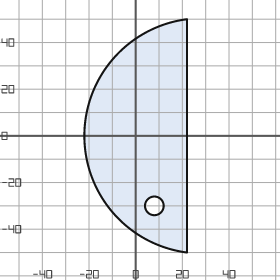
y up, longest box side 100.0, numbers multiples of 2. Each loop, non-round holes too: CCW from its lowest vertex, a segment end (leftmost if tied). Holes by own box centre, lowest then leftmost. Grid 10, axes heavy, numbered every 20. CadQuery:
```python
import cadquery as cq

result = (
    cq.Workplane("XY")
    .moveTo(22.0, -50.0)
    .lineTo(22.0, 50.0)
    .threePointArc((-22.0, 0.0), (22.0, -50.0))
    .close()
    .moveTo(8.0, -30.0)
    .circle(4.0)
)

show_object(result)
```